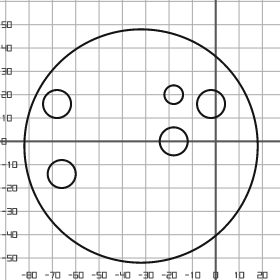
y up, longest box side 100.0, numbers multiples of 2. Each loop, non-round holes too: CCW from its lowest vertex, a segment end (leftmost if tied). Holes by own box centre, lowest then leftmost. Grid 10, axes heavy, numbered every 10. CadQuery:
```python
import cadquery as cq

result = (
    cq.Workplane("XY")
    .moveTo(-32.0, -2.0)
    .circle(50.0)
    .moveTo(-66.0, -14.0)
    .circle(6.0)
    .moveTo(-18.0, 0.0)
    .circle(6.0)
    .moveTo(-68.0, 16.0)
    .circle(6.0)
    .moveTo(-2.0, 16.0)
    .circle(6.0)
    .moveTo(-18.0, 20.0)
    .circle(4.0)
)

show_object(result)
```